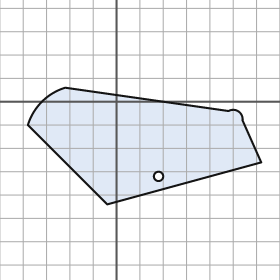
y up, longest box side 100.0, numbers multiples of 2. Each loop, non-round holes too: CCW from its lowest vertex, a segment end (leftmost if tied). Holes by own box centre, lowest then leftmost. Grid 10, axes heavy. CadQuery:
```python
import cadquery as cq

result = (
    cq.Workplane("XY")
    .moveTo(-4.0, -44.0)
    .lineTo(62.0, -26.0)
    .lineTo(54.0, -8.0)
    .threePointArc((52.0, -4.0), (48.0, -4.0))
    .lineTo(-22.0, 6.0)
    .threePointArc((-32.0, 0.0), (-38.0, -10.0))
    .close()
    .moveTo(18.0, -32.0)
    .circle(2.0)
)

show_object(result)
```